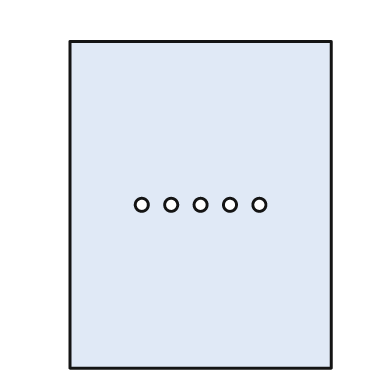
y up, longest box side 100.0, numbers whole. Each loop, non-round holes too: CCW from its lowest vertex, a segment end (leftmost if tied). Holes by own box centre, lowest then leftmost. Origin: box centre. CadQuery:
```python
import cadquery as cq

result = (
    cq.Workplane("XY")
    .moveTo(-40.0, -50.0)
    .lineTo(40.0, -50.0)
    .lineTo(40.0, 50.0)
    .lineTo(-40.0, 50.0)
    .close()
    .moveTo(-18.0, 0.0)
    .circle(2.0)
    .moveTo(-9.0, 0.0)
    .circle(2.0)
    .moveTo(0.0, 0.0)
    .circle(2.0)
    .moveTo(9.0, 0.0)
    .circle(2.0)
    .moveTo(18.0, 0.0)
    .circle(2.0)
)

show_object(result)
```